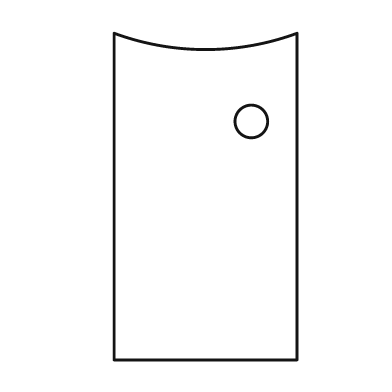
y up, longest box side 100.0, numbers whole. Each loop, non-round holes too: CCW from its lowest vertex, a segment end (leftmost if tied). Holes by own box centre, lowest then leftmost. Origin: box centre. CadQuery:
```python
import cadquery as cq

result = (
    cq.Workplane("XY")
    .moveTo(-28.0, -50.0)
    .lineTo(28.0, -50.0)
    .lineTo(28.0, 50.0)
    .threePointArc((0.0, 45.0), (-28.0, 50.0))
    .close()
    .moveTo(14.0, 23.0)
    .circle(5.0)
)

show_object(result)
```